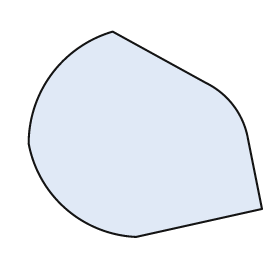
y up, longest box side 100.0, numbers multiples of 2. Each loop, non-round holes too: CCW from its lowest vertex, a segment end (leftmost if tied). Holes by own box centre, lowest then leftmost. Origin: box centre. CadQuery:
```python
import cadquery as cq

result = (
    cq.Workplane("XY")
    .moveTo(-4.0, -44.0)
    .lineTo(50.0, -32.0)
    .lineTo(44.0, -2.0)
    .threePointArc((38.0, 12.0), (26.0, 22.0))
    .lineTo(-14.0, 44.0)
    .threePointArc((-40.0, 26.0), (-50.0, -4.0))
    .threePointArc((-34.0, -32.0), (-4.0, -44.0))
    .close()
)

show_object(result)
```